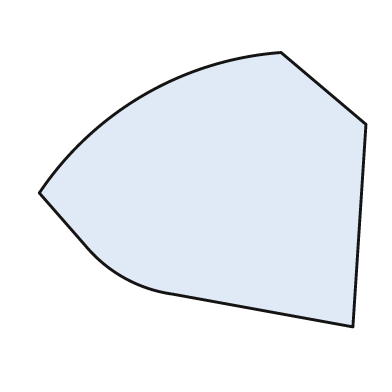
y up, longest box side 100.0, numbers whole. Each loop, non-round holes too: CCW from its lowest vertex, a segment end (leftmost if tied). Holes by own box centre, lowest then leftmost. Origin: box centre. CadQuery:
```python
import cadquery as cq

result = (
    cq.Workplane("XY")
    .moveTo(46.0, -42.0)
    .lineTo(50.0, 20.0)
    .lineTo(24.0, 42.0)
    .threePointArc((-18.0, 29.0), (-50.0, -1.0))
    .lineTo(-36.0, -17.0)
    .threePointArc((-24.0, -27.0), (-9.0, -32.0))
    .close()
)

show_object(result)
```